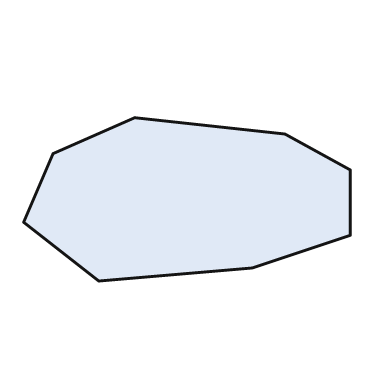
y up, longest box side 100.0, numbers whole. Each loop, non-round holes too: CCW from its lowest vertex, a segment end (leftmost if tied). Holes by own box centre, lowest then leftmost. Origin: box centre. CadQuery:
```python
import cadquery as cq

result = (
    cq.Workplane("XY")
    .moveTo(-27.0, -25.0)
    .lineTo(20.0, -21.0)
    .lineTo(50.0, -11.0)
    .lineTo(50.0, 9.0)
    .lineTo(30.0, 20.0)
    .lineTo(-16.0, 25.0)
    .lineTo(-41.0, 14.0)
    .lineTo(-50.0, -7.0)
    .close()
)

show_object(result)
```